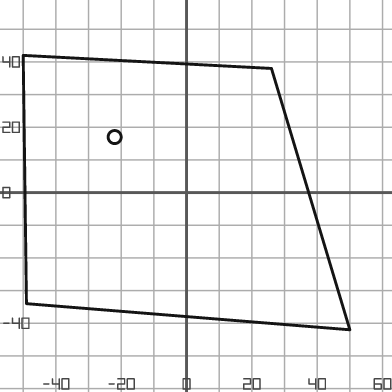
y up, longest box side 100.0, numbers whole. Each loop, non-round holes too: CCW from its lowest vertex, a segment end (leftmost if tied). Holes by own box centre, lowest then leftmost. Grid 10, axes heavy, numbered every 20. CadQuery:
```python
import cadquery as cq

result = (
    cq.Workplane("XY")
    .moveTo(50.0, -42.0)
    .lineTo(26.0, 38.0)
    .lineTo(-50.0, 42.0)
    .lineTo(-49.0, -34.0)
    .close()
    .moveTo(-22.0, 17.0)
    .circle(2.0)
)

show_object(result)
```